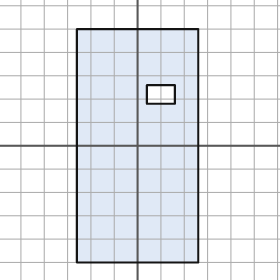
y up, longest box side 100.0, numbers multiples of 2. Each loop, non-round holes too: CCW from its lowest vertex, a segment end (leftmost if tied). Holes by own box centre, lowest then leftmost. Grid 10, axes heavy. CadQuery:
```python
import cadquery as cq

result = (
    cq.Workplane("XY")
    .moveTo(-26.0, -50.0)
    .lineTo(26.0, -50.0)
    .lineTo(26.0, 50.0)
    .lineTo(-26.0, 50.0)
    .close()
    .moveTo(4.0, 18.0)
    .lineTo(16.0, 18.0)
    .lineTo(16.0, 26.0)
    .lineTo(4.0, 26.0)
    .close()
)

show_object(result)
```